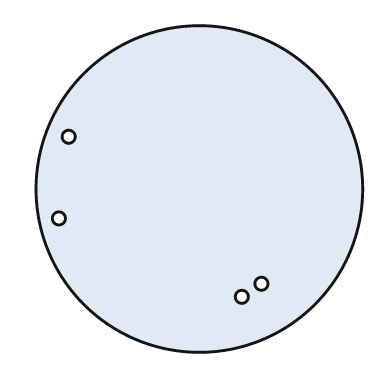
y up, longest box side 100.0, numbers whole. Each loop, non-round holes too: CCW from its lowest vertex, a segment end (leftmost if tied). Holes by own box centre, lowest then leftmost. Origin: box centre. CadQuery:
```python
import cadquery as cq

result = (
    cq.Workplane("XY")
    .moveTo(0.0, 0.0)
    .circle(50.0)
    .moveTo(13.0, -33.0)
    .circle(2.0)
    .moveTo(19.0, -29.0)
    .circle(2.0)
    .moveTo(-43.0, -9.0)
    .circle(2.0)
    .moveTo(-40.0, 16.0)
    .circle(2.0)
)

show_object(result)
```